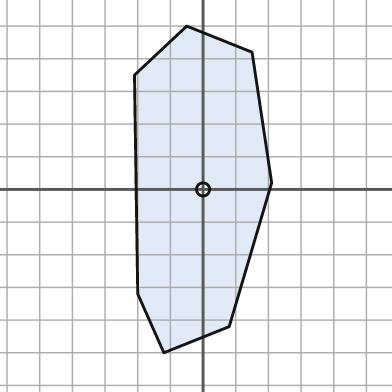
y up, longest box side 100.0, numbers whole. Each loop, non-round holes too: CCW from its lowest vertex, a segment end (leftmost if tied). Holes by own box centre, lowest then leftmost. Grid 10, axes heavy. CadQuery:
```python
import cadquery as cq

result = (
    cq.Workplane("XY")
    .moveTo(-12.0, -50.0)
    .lineTo(8.0, -42.0)
    .lineTo(21.0, 2.0)
    .lineTo(15.0, 42.0)
    .lineTo(-5.0, 50.0)
    .lineTo(-21.0, 35.0)
    .lineTo(-20.0, -32.0)
    .close()
    .moveTo(0.0, 0.0)
    .circle(2.0)
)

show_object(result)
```